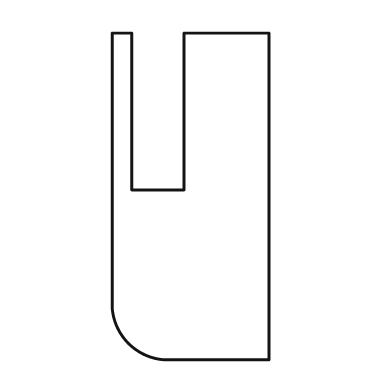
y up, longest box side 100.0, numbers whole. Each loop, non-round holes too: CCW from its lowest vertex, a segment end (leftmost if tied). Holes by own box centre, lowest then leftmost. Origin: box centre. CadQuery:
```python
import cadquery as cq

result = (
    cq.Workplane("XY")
    .moveTo(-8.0, -50.0)
    .lineTo(24.0, -50.0)
    .lineTo(24.0, 50.0)
    .lineTo(-2.0, 50.0)
    .lineTo(-2.0, 2.0)
    .lineTo(-18.0, 2.0)
    .lineTo(-18.0, 50.0)
    .lineTo(-24.0, 50.0)
    .lineTo(-24.0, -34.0)
    .threePointArc((-19.0, -45.0), (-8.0, -50.0))
    .close()
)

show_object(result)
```